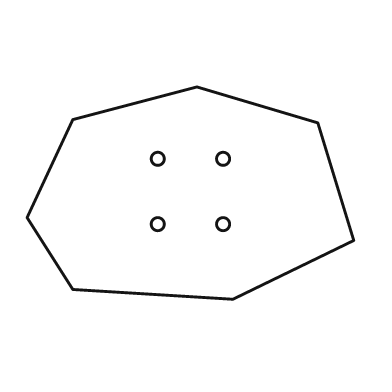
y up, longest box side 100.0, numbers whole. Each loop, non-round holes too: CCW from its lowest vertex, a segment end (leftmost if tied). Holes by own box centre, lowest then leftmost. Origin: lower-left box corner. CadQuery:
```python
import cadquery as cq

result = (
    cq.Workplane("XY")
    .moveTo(63.0, 0.0)
    .lineTo(100.0, 18.0)
    .lineTo(89.0, 54.0)
    .lineTo(52.0, 65.0)
    .lineTo(14.0, 55.0)
    .lineTo(0.0, 25.0)
    .lineTo(14.0, 3.0)
    .close()
    .moveTo(40.0, 23.0)
    .circle(2.0)
    .moveTo(60.0, 23.0)
    .circle(2.0)
    .moveTo(40.0, 43.0)
    .circle(2.0)
    .moveTo(60.0, 43.0)
    .circle(2.0)
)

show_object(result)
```